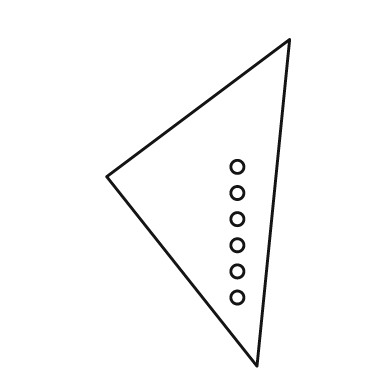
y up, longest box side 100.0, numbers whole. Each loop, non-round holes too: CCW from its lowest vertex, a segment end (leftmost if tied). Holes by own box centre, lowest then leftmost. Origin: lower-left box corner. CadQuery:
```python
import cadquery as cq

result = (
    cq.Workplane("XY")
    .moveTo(46.0, 0.0)
    .lineTo(56.0, 100.0)
    .lineTo(0.0, 58.0)
    .close()
    .moveTo(40.0, 21.0)
    .circle(2.0)
    .moveTo(40.0, 29.0)
    .circle(2.0)
    .moveTo(40.0, 37.0)
    .circle(2.0)
    .moveTo(40.0, 45.0)
    .circle(2.0)
    .moveTo(40.0, 53.0)
    .circle(2.0)
    .moveTo(40.0, 61.0)
    .circle(2.0)
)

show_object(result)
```